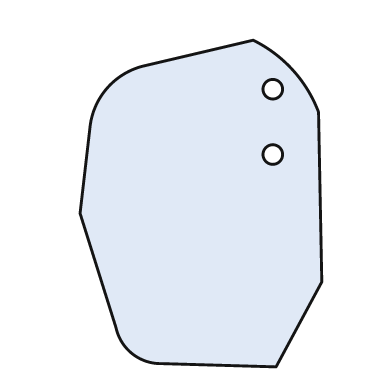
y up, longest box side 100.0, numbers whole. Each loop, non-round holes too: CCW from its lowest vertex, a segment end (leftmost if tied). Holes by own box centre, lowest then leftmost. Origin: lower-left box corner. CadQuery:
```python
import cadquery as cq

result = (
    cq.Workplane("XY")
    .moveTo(60.0, 0.0)
    .lineTo(74.0, 26.0)
    .lineTo(73.0, 78.0)
    .threePointArc((65.0, 91.0), (53.0, 100.0))
    .lineTo(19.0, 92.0)
    .threePointArc((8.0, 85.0), (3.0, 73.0))
    .lineTo(0.0, 47.0)
    .lineTo(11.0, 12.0)
    .threePointArc((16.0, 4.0), (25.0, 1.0))
    .close()
    .moveTo(59.0, 65.0)
    .circle(3.0)
    .moveTo(59.0, 85.0)
    .circle(3.0)
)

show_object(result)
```